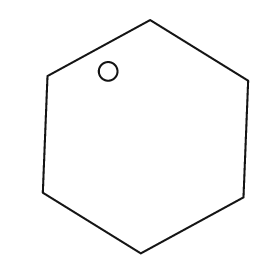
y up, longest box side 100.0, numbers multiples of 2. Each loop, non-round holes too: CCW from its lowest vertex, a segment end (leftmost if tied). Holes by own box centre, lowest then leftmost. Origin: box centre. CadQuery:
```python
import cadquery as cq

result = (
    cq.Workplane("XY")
    .moveTo(-2.0, -50.0)
    .lineTo(42.0, -26.0)
    .lineTo(44.0, 24.0)
    .lineTo(2.0, 50.0)
    .lineTo(-42.0, 26.0)
    .lineTo(-44.0, -24.0)
    .close()
    .moveTo(-16.0, 28.0)
    .circle(4.0)
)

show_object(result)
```